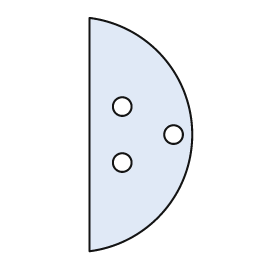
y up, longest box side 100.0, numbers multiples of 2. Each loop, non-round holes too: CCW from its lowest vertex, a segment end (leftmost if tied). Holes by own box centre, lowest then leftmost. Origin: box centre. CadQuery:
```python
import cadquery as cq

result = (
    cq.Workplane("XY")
    .moveTo(-22.0, -50.0)
    .threePointArc((22.0, 0.0), (-22.0, 50.0))
    .close()
    .moveTo(-8.0, -12.0)
    .circle(4.0)
    .moveTo(14.0, 0.0)
    .circle(4.0)
    .moveTo(-8.0, 12.0)
    .circle(4.0)
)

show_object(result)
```